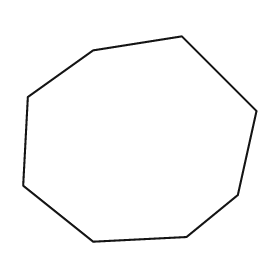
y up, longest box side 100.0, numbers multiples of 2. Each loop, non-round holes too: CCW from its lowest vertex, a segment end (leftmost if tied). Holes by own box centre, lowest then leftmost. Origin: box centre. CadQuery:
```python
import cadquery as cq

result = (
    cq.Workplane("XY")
    .moveTo(-20.0, -44.0)
    .lineTo(20.0, -42.0)
    .lineTo(42.0, -24.0)
    .lineTo(50.0, 12.0)
    .lineTo(18.0, 44.0)
    .lineTo(-20.0, 38.0)
    .lineTo(-48.0, 18.0)
    .lineTo(-50.0, -20.0)
    .close()
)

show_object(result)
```